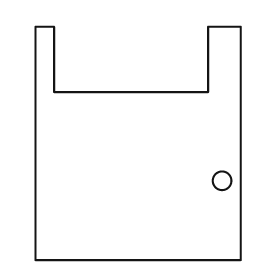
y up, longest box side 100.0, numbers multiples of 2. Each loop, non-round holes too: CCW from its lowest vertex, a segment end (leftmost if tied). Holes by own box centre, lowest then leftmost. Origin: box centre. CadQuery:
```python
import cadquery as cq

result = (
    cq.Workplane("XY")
    .moveTo(-44.0, -50.0)
    .lineTo(44.0, -50.0)
    .lineTo(44.0, 50.0)
    .lineTo(30.0, 50.0)
    .lineTo(30.0, 22.0)
    .lineTo(-36.0, 22.0)
    .lineTo(-36.0, 50.0)
    .lineTo(-44.0, 50.0)
    .close()
    .moveTo(36.0, -16.0)
    .circle(4.0)
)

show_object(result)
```